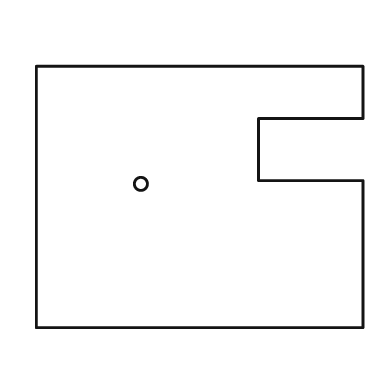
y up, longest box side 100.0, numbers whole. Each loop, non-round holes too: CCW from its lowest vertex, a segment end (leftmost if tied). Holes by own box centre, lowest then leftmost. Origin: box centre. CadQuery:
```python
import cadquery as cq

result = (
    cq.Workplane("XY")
    .moveTo(-50.0, -40.0)
    .lineTo(50.0, -40.0)
    .lineTo(50.0, 5.0)
    .lineTo(18.0, 5.0)
    .lineTo(18.0, 24.0)
    .lineTo(50.0, 24.0)
    .lineTo(50.0, 40.0)
    .lineTo(-50.0, 40.0)
    .close()
    .moveTo(-18.0, 4.0)
    .circle(2.0)
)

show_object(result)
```